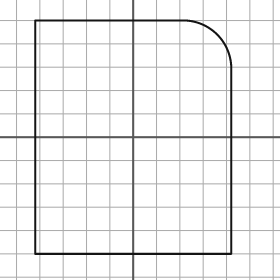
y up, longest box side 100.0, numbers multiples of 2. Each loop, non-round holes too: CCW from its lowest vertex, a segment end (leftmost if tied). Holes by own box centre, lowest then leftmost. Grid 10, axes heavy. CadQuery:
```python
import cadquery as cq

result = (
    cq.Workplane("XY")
    .moveTo(-42.0, -50.0)
    .lineTo(42.0, -50.0)
    .lineTo(42.0, 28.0)
    .threePointArc((36.0, 44.0), (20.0, 50.0))
    .lineTo(-42.0, 50.0)
    .close()
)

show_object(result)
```